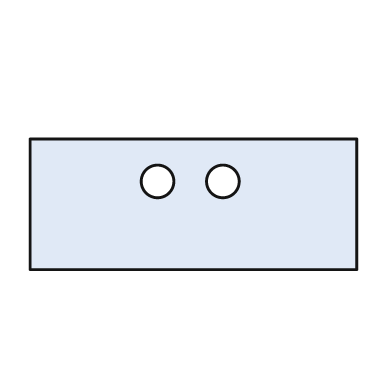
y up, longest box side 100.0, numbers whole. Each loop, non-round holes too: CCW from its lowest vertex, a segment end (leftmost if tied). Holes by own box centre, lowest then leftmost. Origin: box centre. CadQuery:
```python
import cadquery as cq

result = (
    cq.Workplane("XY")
    .moveTo(-50.0, -20.0)
    .lineTo(50.0, -20.0)
    .lineTo(50.0, 20.0)
    .lineTo(-50.0, 20.0)
    .close()
    .moveTo(-11.0, 7.0)
    .circle(5.0)
    .moveTo(9.0, 7.0)
    .circle(5.0)
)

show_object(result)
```